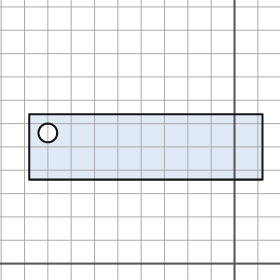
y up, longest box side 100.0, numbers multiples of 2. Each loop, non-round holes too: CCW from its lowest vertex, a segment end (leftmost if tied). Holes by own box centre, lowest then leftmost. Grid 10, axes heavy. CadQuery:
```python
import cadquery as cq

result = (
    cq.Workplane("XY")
    .moveTo(-88.0, 36.0)
    .lineTo(12.0, 36.0)
    .lineTo(12.0, 64.0)
    .lineTo(-88.0, 64.0)
    .close()
    .moveTo(-80.0, 56.0)
    .circle(4.0)
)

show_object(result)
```